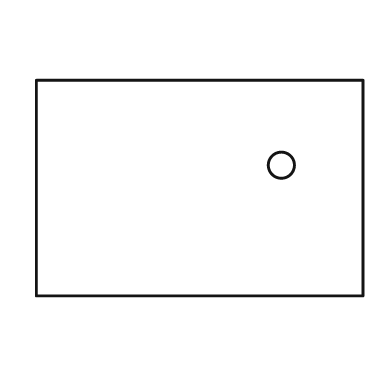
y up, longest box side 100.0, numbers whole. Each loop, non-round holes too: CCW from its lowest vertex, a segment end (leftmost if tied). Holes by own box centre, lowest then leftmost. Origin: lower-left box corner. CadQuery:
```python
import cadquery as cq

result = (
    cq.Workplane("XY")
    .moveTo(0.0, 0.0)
    .lineTo(100.0, 0.0)
    .lineTo(100.0, 66.0)
    .lineTo(0.0, 66.0)
    .close()
    .moveTo(75.0, 40.0)
    .circle(4.0)
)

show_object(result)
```